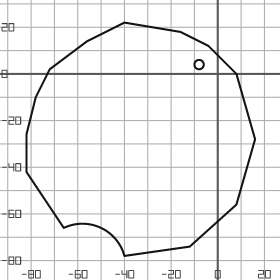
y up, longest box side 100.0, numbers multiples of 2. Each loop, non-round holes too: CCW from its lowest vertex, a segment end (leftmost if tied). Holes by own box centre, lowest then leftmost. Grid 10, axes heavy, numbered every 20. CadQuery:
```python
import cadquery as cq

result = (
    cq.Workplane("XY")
    .moveTo(-40.0, -78.0)
    .lineTo(-12.0, -74.0)
    .lineTo(8.0, -56.0)
    .lineTo(16.0, -28.0)
    .lineTo(8.0, 0.0)
    .lineTo(-4.0, 12.0)
    .lineTo(-16.0, 18.0)
    .lineTo(-40.0, 22.0)
    .lineTo(-56.0, 14.0)
    .lineTo(-72.0, 2.0)
    .lineTo(-78.0, -10.0)
    .lineTo(-82.0, -26.0)
    .lineTo(-82.0, -42.0)
    .lineTo(-66.0, -66.0)
    .threePointArc((-50.0, -66.0), (-40.0, -78.0))
    .close()
    .moveTo(-8.0, 4.0)
    .circle(2.0)
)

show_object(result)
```